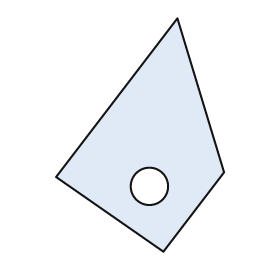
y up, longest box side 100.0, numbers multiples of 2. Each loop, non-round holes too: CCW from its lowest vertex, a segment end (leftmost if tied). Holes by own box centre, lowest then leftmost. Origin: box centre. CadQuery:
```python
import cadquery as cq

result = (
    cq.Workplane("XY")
    .moveTo(10.0, -50.0)
    .lineTo(36.0, -16.0)
    .lineTo(16.0, 50.0)
    .lineTo(-36.0, -18.0)
    .close()
    .moveTo(4.0, -22.0)
    .circle(8.0)
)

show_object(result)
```